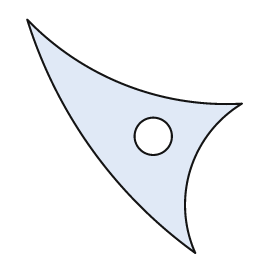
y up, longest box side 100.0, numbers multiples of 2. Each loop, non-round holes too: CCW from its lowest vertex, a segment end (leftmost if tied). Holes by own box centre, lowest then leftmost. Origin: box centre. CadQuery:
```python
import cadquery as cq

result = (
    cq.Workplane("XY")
    .moveTo(26.0, -50.0)
    .threePointArc((24.0, -14.0), (46.0, 14.0))
    .threePointArc((-4.0, 22.0), (-46.0, 50.0))
    .threePointArc((-18.0, -6.0), (26.0, -50.0))
    .close()
    .moveTo(8.0, 0.0)
    .circle(8.0)
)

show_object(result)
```